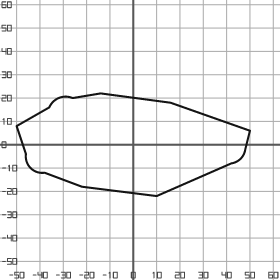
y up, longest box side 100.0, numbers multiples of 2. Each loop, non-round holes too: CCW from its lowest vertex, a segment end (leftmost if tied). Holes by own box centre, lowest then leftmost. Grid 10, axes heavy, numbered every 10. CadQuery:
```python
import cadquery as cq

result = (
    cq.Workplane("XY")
    .moveTo(10.0, -22.0)
    .lineTo(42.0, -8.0)
    .threePointArc((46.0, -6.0), (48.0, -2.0))
    .lineTo(50.0, 6.0)
    .lineTo(16.0, 18.0)
    .lineTo(-14.0, 22.0)
    .lineTo(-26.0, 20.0)
    .threePointArc((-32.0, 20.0), (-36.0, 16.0))
    .lineTo(-50.0, 8.0)
    .lineTo(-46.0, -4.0)
    .threePointArc((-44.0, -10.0), (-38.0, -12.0))
    .lineTo(-22.0, -18.0)
    .close()
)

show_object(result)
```